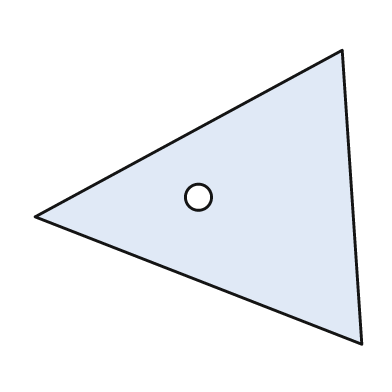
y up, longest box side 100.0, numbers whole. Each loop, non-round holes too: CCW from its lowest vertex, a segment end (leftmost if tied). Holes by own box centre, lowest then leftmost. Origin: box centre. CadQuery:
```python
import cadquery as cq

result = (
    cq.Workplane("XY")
    .moveTo(50.0, -45.0)
    .lineTo(44.0, 45.0)
    .lineTo(-50.0, -6.0)
    .close()
    .moveTo(0.0, 0.0)
    .circle(4.0)
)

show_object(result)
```